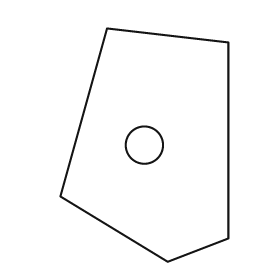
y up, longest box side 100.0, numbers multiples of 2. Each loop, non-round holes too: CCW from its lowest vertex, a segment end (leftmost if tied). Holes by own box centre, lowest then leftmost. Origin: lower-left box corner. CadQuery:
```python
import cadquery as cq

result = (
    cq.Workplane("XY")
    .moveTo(46.0, 0.0)
    .lineTo(72.0, 10.0)
    .lineTo(72.0, 94.0)
    .lineTo(20.0, 100.0)
    .lineTo(0.0, 28.0)
    .close()
    .moveTo(36.0, 50.0)
    .circle(8.0)
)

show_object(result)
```